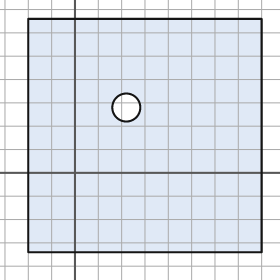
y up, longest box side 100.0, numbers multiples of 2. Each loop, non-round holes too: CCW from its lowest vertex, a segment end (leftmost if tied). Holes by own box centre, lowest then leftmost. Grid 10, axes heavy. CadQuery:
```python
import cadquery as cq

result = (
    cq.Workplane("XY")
    .moveTo(-20.0, -34.0)
    .lineTo(80.0, -34.0)
    .lineTo(80.0, 66.0)
    .lineTo(-20.0, 66.0)
    .close()
    .moveTo(22.0, 28.0)
    .circle(6.0)
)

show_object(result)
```